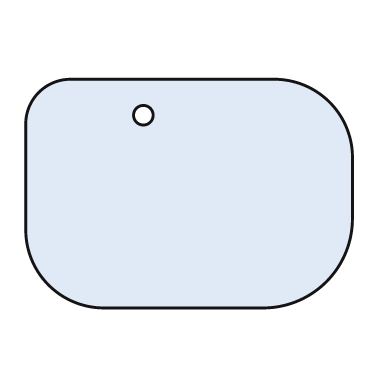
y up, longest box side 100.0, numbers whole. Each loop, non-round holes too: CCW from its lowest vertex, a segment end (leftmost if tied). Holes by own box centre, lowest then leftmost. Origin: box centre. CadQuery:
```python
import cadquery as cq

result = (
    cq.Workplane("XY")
    .moveTo(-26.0, -35.0)
    .lineTo(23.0, -35.0)
    .threePointArc((42.0, -27.0), (50.0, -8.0))
    .lineTo(50.0, 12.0)
    .threePointArc((43.0, 28.0), (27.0, 35.0))
    .lineTo(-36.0, 35.0)
    .threePointArc((-46.0, 31.0), (-50.0, 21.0))
    .lineTo(-50.0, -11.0)
    .threePointArc((-43.0, -28.0), (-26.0, -35.0))
    .close()
    .moveTo(-14.0, 24.0)
    .circle(3.0)
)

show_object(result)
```